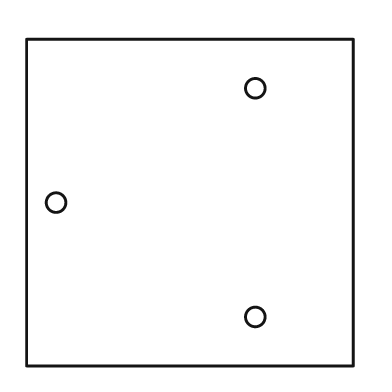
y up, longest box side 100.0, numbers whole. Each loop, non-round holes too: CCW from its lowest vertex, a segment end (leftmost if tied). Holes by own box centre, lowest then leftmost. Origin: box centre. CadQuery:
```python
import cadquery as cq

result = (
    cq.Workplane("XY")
    .moveTo(-50.0, -50.0)
    .lineTo(50.0, -50.0)
    .lineTo(50.0, 50.0)
    .lineTo(-50.0, 50.0)
    .close()
    .moveTo(20.0, -35.0)
    .circle(3.0)
    .moveTo(-41.0, 0.0)
    .circle(3.0)
    .moveTo(20.0, 35.0)
    .circle(3.0)
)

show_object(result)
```